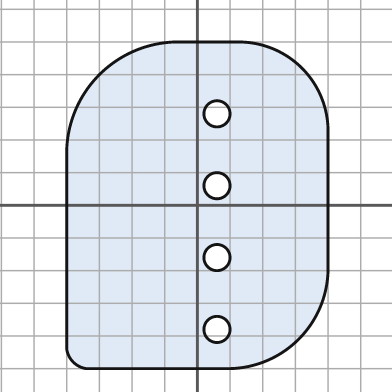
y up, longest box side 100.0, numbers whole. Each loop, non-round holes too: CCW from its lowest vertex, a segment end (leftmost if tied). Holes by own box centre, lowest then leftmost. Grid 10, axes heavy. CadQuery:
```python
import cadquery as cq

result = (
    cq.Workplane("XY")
    .moveTo(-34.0, -50.0)
    .lineTo(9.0, -50.0)
    .threePointArc((31.0, -41.0), (40.0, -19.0))
    .lineTo(40.0, 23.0)
    .threePointArc((32.0, 42.0), (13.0, 50.0))
    .lineTo(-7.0, 50.0)
    .threePointArc((-30.0, 40.0), (-40.0, 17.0))
    .lineTo(-40.0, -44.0)
    .threePointArc((-38.0, -48.0), (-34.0, -50.0))
    .close()
    .moveTo(6.0, -38.0)
    .circle(4.0)
    .moveTo(6.0, -16.0)
    .circle(4.0)
    .moveTo(6.0, 6.0)
    .circle(4.0)
    .moveTo(6.0, 28.0)
    .circle(4.0)
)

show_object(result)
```